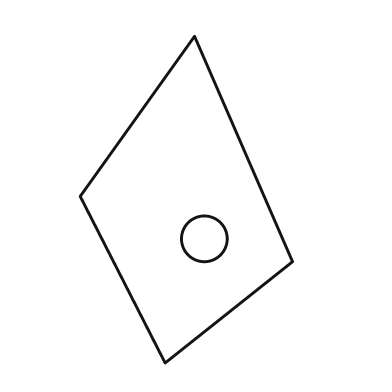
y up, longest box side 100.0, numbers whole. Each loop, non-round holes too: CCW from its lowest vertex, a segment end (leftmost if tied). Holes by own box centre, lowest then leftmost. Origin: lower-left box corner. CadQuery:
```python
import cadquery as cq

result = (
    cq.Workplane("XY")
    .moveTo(26.0, 0.0)
    .lineTo(65.0, 31.0)
    .lineTo(35.0, 100.0)
    .lineTo(0.0, 51.0)
    .close()
    .moveTo(38.0, 38.0)
    .circle(7.0)
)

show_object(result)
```